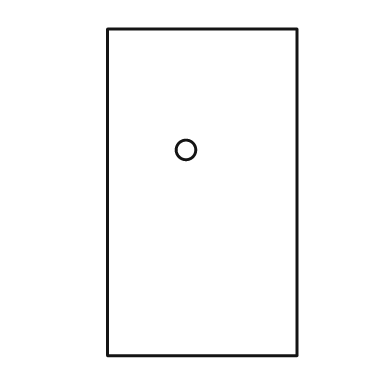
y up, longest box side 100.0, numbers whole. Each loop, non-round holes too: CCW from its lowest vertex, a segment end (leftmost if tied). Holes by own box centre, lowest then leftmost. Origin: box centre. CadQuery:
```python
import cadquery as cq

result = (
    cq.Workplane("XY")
    .moveTo(-29.0, -50.0)
    .lineTo(29.0, -50.0)
    .lineTo(29.0, 50.0)
    .lineTo(-29.0, 50.0)
    .close()
    .moveTo(-5.0, 13.0)
    .circle(3.0)
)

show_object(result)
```